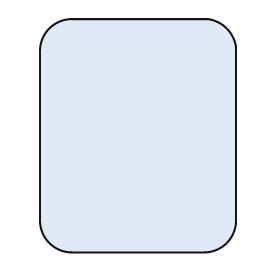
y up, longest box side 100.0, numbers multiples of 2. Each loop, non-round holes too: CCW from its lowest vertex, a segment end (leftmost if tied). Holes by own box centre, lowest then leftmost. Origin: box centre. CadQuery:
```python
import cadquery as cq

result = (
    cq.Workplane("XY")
    .moveTo(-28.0, -50.0)
    .lineTo(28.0, -50.0)
    .threePointArc((38.0, -46.0), (42.0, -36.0))
    .lineTo(42.0, 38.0)
    .threePointArc((38.0, 46.0), (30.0, 50.0))
    .lineTo(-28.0, 50.0)
    .threePointArc((-38.0, 46.0), (-42.0, 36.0))
    .lineTo(-42.0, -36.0)
    .threePointArc((-38.0, -46.0), (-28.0, -50.0))
    .close()
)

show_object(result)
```